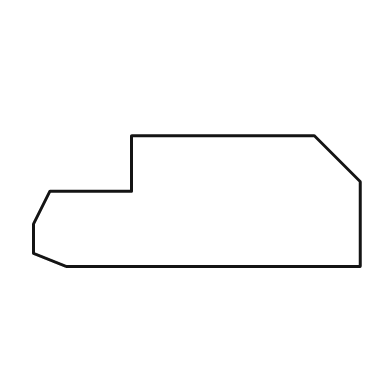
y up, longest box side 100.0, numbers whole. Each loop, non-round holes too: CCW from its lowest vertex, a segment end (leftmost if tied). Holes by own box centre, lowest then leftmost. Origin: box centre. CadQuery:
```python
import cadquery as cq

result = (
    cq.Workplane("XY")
    .moveTo(-40.0, -20.0)
    .lineTo(50.0, -20.0)
    .lineTo(50.0, 6.0)
    .lineTo(36.0, 20.0)
    .lineTo(-20.0, 20.0)
    .lineTo(-20.0, 3.0)
    .lineTo(-45.0, 3.0)
    .lineTo(-50.0, -7.0)
    .lineTo(-50.0, -16.0)
    .close()
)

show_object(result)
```